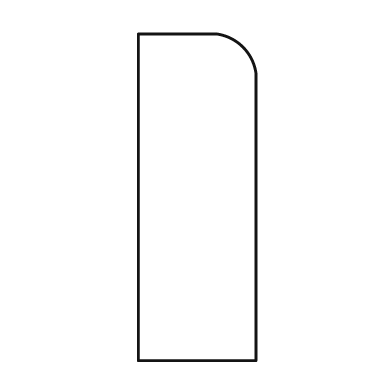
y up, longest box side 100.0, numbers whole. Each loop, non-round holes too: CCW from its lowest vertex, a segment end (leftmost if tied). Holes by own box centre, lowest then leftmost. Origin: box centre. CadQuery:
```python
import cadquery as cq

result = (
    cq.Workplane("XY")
    .moveTo(-18.0, -50.0)
    .lineTo(18.0, -50.0)
    .lineTo(18.0, 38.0)
    .threePointArc((14.0, 46.0), (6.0, 50.0))
    .lineTo(-18.0, 50.0)
    .close()
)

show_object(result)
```